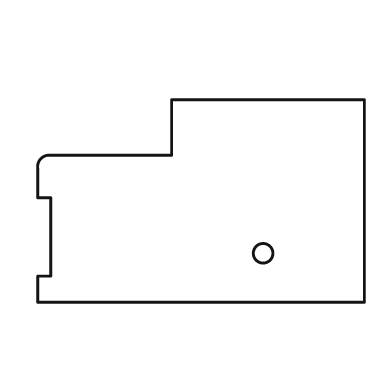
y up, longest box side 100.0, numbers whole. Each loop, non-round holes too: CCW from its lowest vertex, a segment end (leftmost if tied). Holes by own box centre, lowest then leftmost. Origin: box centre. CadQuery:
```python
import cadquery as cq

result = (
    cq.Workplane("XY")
    .moveTo(-50.0, -31.0)
    .lineTo(50.0, -31.0)
    .lineTo(50.0, 31.0)
    .lineTo(-9.0, 31.0)
    .lineTo(-9.0, 14.0)
    .lineTo(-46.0, 14.0)
    .threePointArc((-49.0, 13.0), (-50.0, 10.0))
    .lineTo(-50.0, 1.0)
    .lineTo(-46.0, 1.0)
    .lineTo(-46.0, -23.0)
    .lineTo(-50.0, -23.0)
    .close()
    .moveTo(19.0, -16.0)
    .circle(3.0)
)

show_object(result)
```